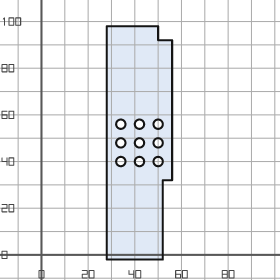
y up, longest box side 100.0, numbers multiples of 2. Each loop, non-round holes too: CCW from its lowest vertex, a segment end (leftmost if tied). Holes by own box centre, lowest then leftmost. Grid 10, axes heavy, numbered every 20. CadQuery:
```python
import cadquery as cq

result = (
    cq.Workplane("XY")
    .moveTo(28.0, -2.0)
    .lineTo(52.0, -2.0)
    .lineTo(52.0, 32.0)
    .lineTo(56.0, 32.0)
    .lineTo(56.0, 92.0)
    .lineTo(50.0, 92.0)
    .lineTo(50.0, 98.0)
    .lineTo(28.0, 98.0)
    .close()
    .moveTo(34.0, 40.0)
    .circle(2.0)
    .moveTo(42.0, 40.0)
    .circle(2.0)
    .moveTo(50.0, 40.0)
    .circle(2.0)
    .moveTo(34.0, 48.0)
    .circle(2.0)
    .moveTo(42.0, 48.0)
    .circle(2.0)
    .moveTo(50.0, 48.0)
    .circle(2.0)
    .moveTo(34.0, 56.0)
    .circle(2.0)
    .moveTo(42.0, 56.0)
    .circle(2.0)
    .moveTo(50.0, 56.0)
    .circle(2.0)
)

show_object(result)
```